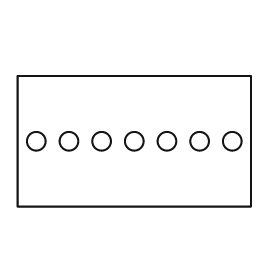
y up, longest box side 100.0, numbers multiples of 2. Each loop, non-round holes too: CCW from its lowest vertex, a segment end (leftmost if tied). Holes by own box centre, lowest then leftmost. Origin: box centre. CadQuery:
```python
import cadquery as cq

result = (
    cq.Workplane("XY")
    .moveTo(-50.0, -28.0)
    .lineTo(50.0, -28.0)
    .lineTo(50.0, 28.0)
    .lineTo(-50.0, 28.0)
    .close()
    .moveTo(-42.0, 0.0)
    .circle(4.0)
    .moveTo(-28.0, 0.0)
    .circle(4.0)
    .moveTo(-14.0, 0.0)
    .circle(4.0)
    .moveTo(0.0, 0.0)
    .circle(4.0)
    .moveTo(14.0, 0.0)
    .circle(4.0)
    .moveTo(28.0, 0.0)
    .circle(4.0)
    .moveTo(42.0, 0.0)
    .circle(4.0)
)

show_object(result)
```